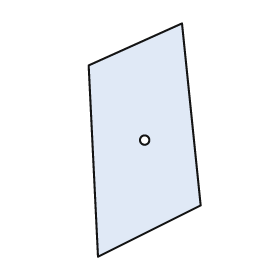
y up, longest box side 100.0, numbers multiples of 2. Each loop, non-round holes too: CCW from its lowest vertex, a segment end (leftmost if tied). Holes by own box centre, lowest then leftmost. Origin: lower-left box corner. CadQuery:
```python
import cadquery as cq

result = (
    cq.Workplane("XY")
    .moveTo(4.0, 0.0)
    .lineTo(48.0, 22.0)
    .lineTo(40.0, 100.0)
    .lineTo(0.0, 82.0)
    .close()
    .moveTo(24.0, 50.0)
    .circle(2.0)
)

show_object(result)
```